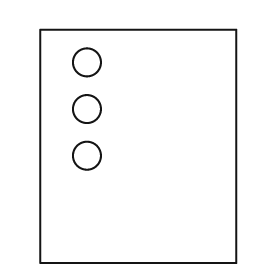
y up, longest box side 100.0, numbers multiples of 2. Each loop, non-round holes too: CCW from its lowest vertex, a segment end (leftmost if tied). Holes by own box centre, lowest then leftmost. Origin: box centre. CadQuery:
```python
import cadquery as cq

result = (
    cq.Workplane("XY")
    .moveTo(-42.0, -50.0)
    .lineTo(42.0, -50.0)
    .lineTo(42.0, 50.0)
    .lineTo(-42.0, 50.0)
    .close()
    .moveTo(-22.0, -4.0)
    .circle(6.0)
    .moveTo(-22.0, 16.0)
    .circle(6.0)
    .moveTo(-22.0, 36.0)
    .circle(6.0)
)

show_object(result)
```